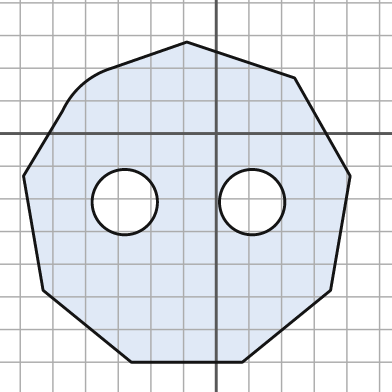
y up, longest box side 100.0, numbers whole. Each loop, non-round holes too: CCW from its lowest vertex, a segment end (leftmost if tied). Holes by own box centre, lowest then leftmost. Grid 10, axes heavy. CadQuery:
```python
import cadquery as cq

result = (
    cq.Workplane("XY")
    .moveTo(-26.0, -70.0)
    .lineTo(8.0, -70.0)
    .lineTo(35.0, -48.0)
    .lineTo(41.0, -13.0)
    .lineTo(24.0, 17.0)
    .lineTo(-9.0, 28.0)
    .lineTo(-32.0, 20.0)
    .threePointArc((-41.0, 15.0), (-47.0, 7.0))
    .lineTo(-59.0, -13.0)
    .lineTo(-53.0, -48.0)
    .close()
    .moveTo(-28.0, -21.0)
    .circle(10.0)
    .moveTo(11.0, -21.0)
    .circle(10.0)
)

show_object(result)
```